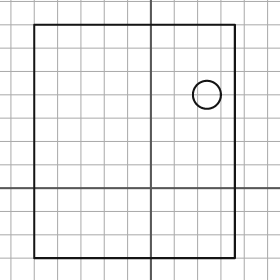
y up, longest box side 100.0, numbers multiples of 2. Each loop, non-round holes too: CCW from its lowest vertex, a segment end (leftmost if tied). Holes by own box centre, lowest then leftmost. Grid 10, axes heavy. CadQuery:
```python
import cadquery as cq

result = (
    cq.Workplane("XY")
    .moveTo(-50.0, -30.0)
    .lineTo(36.0, -30.0)
    .lineTo(36.0, 70.0)
    .lineTo(-50.0, 70.0)
    .close()
    .moveTo(24.0, 40.0)
    .circle(6.0)
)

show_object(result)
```